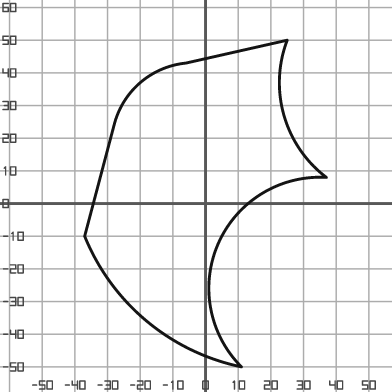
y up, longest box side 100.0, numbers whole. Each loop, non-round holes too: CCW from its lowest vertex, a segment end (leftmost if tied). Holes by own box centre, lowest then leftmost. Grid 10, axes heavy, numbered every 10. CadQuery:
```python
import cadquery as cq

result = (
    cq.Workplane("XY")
    .moveTo(11.0, -50.0)
    .threePointArc((4.0, -12.0), (37.0, 8.0))
    .threePointArc((24.0, 27.0), (25.0, 50.0))
    .lineTo(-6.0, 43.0)
    .threePointArc((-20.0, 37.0), (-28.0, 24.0))
    .lineTo(-37.0, -10.0)
    .threePointArc((-18.0, -36.0), (11.0, -50.0))
    .close()
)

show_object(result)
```